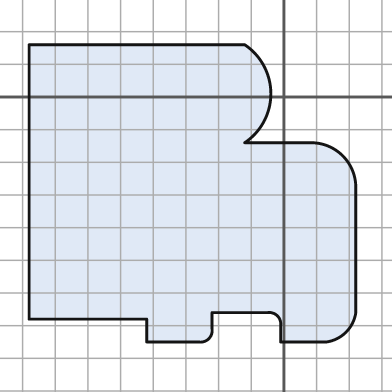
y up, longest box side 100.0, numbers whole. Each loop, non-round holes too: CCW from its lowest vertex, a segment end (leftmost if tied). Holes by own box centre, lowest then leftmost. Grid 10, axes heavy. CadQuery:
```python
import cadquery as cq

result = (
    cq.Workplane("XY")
    .moveTo(-42.0, -75.0)
    .lineTo(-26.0, -75.0)
    .threePointArc((-23.0, -74.0), (-22.0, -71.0))
    .lineTo(-22.0, -66.0)
    .lineTo(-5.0, -66.0)
    .threePointArc((-2.0, -67.0), (-1.0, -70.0))
    .lineTo(-1.0, -75.0)
    .lineTo(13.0, -75.0)
    .threePointArc((19.0, -72.0), (22.0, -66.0))
    .lineTo(22.0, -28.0)
    .threePointArc((18.0, -18.0), (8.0, -14.0))
    .lineTo(-12.0, -14.0)
    .threePointArc((-4.0, 1.0), (-12.0, 16.0))
    .lineTo(-78.0, 16.0)
    .lineTo(-78.0, -68.0)
    .lineTo(-42.0, -68.0)
    .close()
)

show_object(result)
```